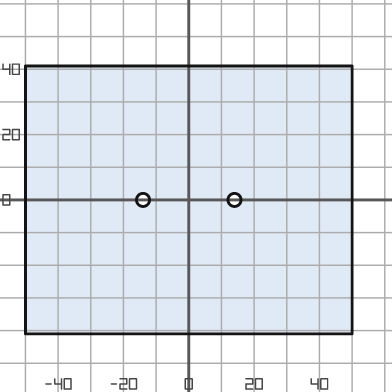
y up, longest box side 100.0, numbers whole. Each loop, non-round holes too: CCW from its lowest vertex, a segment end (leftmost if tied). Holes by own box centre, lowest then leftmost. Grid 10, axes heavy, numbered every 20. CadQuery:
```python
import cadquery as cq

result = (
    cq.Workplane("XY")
    .moveTo(-50.0, -41.0)
    .lineTo(50.0, -41.0)
    .lineTo(50.0, 41.0)
    .lineTo(-50.0, 41.0)
    .close()
    .moveTo(-14.0, 0.0)
    .circle(2.0)
    .moveTo(14.0, 0.0)
    .circle(2.0)
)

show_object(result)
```